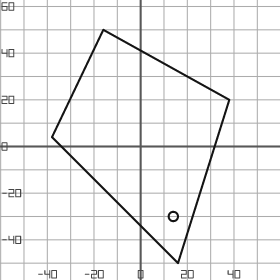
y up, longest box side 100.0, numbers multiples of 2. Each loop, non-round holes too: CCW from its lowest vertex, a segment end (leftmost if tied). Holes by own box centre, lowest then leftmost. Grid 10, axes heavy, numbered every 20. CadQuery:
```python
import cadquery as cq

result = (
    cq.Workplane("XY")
    .moveTo(16.0, -50.0)
    .lineTo(38.0, 20.0)
    .lineTo(-16.0, 50.0)
    .lineTo(-38.0, 4.0)
    .close()
    .moveTo(14.0, -30.0)
    .circle(2.0)
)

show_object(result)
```